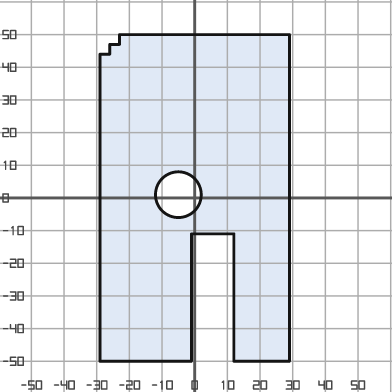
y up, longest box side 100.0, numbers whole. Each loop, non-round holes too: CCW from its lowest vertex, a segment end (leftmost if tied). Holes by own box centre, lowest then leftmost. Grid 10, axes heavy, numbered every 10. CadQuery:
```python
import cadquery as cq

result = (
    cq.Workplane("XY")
    .moveTo(-29.0, -50.0)
    .lineTo(-1.0, -50.0)
    .lineTo(-1.0, -11.0)
    .lineTo(12.0, -11.0)
    .lineTo(12.0, -50.0)
    .lineTo(29.0, -50.0)
    .lineTo(29.0, 50.0)
    .lineTo(-23.0, 50.0)
    .lineTo(-23.0, 47.0)
    .lineTo(-26.0, 47.0)
    .lineTo(-26.0, 44.0)
    .lineTo(-29.0, 44.0)
    .close()
    .moveTo(-5.0, 1.0)
    .circle(7.0)
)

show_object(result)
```